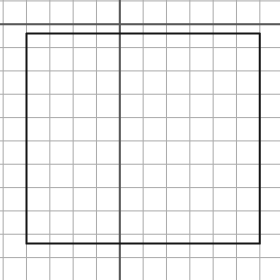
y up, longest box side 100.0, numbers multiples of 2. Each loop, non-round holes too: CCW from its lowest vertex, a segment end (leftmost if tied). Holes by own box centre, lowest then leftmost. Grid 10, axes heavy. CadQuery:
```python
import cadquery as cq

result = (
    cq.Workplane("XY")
    .moveTo(-40.0, -94.0)
    .lineTo(60.0, -94.0)
    .lineTo(60.0, -4.0)
    .lineTo(-40.0, -4.0)
    .close()
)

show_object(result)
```